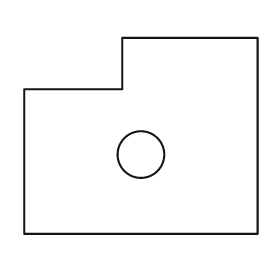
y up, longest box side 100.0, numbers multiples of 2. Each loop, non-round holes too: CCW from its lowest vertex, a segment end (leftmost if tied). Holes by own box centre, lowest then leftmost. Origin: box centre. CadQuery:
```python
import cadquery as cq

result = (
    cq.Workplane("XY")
    .moveTo(-50.0, -42.0)
    .lineTo(50.0, -42.0)
    .lineTo(50.0, 42.0)
    .lineTo(-8.0, 42.0)
    .lineTo(-8.0, 20.0)
    .lineTo(-50.0, 20.0)
    .close()
    .moveTo(0.0, -8.0)
    .circle(10.0)
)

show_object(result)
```